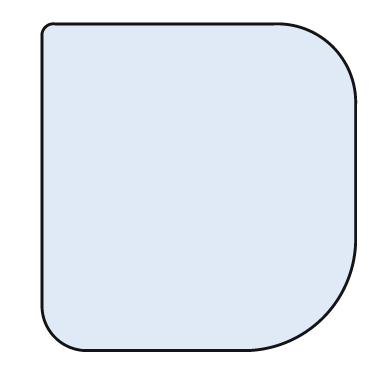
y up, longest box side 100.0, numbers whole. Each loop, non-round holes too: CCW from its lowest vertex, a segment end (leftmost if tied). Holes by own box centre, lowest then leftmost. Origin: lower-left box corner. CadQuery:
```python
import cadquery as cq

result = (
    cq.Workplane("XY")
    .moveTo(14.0, 0.0)
    .lineTo(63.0, 0.0)
    .threePointArc((86.0, 10.0), (96.0, 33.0))
    .lineTo(96.0, 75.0)
    .threePointArc((89.0, 93.0), (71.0, 100.0))
    .lineTo(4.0, 100.0)
    .threePointArc((1.0, 99.0), (0.0, 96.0))
    .lineTo(0.0, 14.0)
    .threePointArc((4.0, 4.0), (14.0, 0.0))
    .close()
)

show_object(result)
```